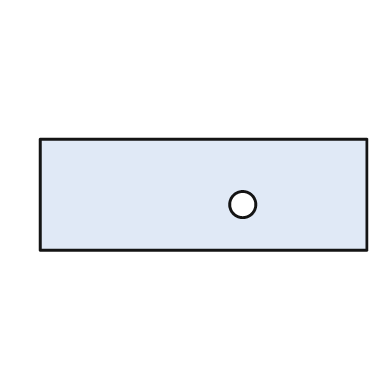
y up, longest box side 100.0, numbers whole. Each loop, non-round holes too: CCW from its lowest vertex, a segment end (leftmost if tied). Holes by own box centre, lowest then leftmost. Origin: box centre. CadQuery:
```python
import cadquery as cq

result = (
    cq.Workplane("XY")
    .moveTo(-50.0, -17.0)
    .lineTo(50.0, -17.0)
    .lineTo(50.0, 17.0)
    .lineTo(-50.0, 17.0)
    .close()
    .moveTo(12.0, -3.0)
    .circle(4.0)
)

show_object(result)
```